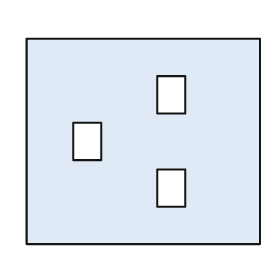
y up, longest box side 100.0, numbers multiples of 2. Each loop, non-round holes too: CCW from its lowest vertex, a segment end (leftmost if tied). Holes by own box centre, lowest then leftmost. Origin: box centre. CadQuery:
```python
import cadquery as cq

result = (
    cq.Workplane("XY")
    .moveTo(-50.0, -44.0)
    .lineTo(50.0, -44.0)
    .lineTo(50.0, 44.0)
    .lineTo(-50.0, 44.0)
    .close()
    .moveTo(6.0, -28.0)
    .lineTo(18.0, -28.0)
    .lineTo(18.0, -12.0)
    .lineTo(6.0, -12.0)
    .close()
    .moveTo(-30.0, -8.0)
    .lineTo(-18.0, -8.0)
    .lineTo(-18.0, 8.0)
    .lineTo(-30.0, 8.0)
    .close()
    .moveTo(6.0, 12.0)
    .lineTo(18.0, 12.0)
    .lineTo(18.0, 28.0)
    .lineTo(6.0, 28.0)
    .close()
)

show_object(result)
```